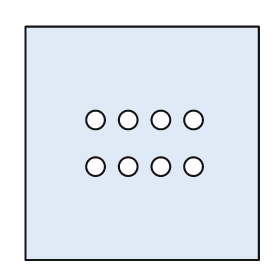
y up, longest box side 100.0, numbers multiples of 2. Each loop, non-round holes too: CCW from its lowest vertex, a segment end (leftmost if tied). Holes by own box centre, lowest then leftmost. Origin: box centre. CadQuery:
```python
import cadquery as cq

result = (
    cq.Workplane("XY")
    .moveTo(-50.0, -50.0)
    .lineTo(50.0, -50.0)
    .lineTo(50.0, 50.0)
    .lineTo(-50.0, 50.0)
    .close()
    .moveTo(-20.0, -10.0)
    .circle(4.0)
    .moveTo(-6.0, -10.0)
    .circle(4.0)
    .moveTo(8.0, -10.0)
    .circle(4.0)
    .moveTo(22.0, -10.0)
    .circle(4.0)
    .moveTo(-20.0, 10.0)
    .circle(4.0)
    .moveTo(-6.0, 10.0)
    .circle(4.0)
    .moveTo(8.0, 10.0)
    .circle(4.0)
    .moveTo(22.0, 10.0)
    .circle(4.0)
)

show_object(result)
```